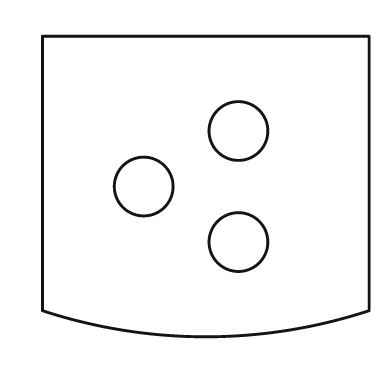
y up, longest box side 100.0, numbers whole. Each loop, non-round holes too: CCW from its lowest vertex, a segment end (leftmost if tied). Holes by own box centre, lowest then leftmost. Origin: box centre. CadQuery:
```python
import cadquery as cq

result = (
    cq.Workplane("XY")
    .moveTo(-50.0, -38.0)
    .threePointArc((0.0, -46.0), (50.0, -38.0))
    .lineTo(50.0, 46.0)
    .lineTo(-50.0, 46.0)
    .close()
    .moveTo(10.0, -17.0)
    .circle(9.0)
    .moveTo(-19.0, 0.0)
    .circle(9.0)
    .moveTo(10.0, 17.0)
    .circle(9.0)
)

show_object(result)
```